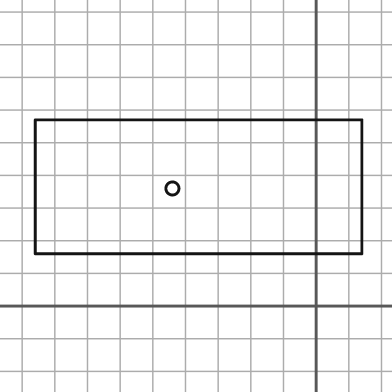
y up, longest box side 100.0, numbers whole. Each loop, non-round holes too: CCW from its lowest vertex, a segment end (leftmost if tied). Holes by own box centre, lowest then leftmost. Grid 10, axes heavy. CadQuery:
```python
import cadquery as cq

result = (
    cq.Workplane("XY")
    .moveTo(-86.0, 16.0)
    .lineTo(14.0, 16.0)
    .lineTo(14.0, 57.0)
    .lineTo(-86.0, 57.0)
    .close()
    .moveTo(-44.0, 36.0)
    .circle(2.0)
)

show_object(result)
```